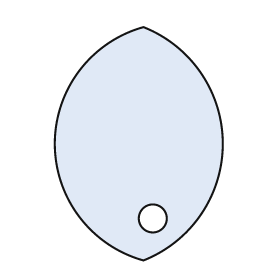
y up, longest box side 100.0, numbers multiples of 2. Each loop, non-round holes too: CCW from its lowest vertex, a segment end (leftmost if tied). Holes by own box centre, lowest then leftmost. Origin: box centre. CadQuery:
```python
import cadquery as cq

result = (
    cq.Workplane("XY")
    .moveTo(2.0, -50.0)
    .threePointArc((36.0, 0.0), (2.0, 50.0))
    .threePointArc((-36.0, 0.0), (2.0, -50.0))
    .close()
    .moveTo(6.0, -32.0)
    .circle(6.0)
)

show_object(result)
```